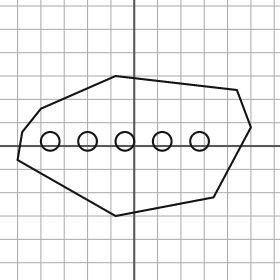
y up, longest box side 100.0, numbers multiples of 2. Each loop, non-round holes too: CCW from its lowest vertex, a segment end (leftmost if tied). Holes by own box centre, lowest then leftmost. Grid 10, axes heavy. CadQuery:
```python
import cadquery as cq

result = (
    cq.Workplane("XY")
    .moveTo(-8.0, -30.0)
    .lineTo(34.0, -22.0)
    .lineTo(50.0, 8.0)
    .lineTo(44.0, 24.0)
    .lineTo(-8.0, 30.0)
    .lineTo(-40.0, 16.0)
    .lineTo(-48.0, 6.0)
    .lineTo(-50.0, -6.0)
    .close()
    .moveTo(-36.0, 2.0)
    .circle(4.0)
    .moveTo(-20.0, 2.0)
    .circle(4.0)
    .moveTo(-4.0, 2.0)
    .circle(4.0)
    .moveTo(12.0, 2.0)
    .circle(4.0)
    .moveTo(28.0, 2.0)
    .circle(4.0)
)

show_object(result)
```